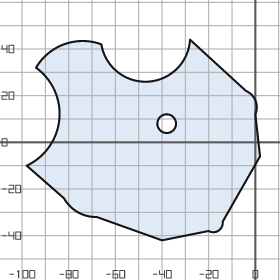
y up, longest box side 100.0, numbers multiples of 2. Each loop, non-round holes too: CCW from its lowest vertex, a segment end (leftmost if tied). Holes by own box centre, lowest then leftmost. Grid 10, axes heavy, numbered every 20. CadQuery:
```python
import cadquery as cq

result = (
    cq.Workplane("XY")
    .moveTo(-40.0, -42.0)
    .lineTo(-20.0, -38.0)
    .threePointArc((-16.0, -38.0), (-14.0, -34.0))
    .lineTo(2.0, -6.0)
    .lineTo(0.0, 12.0)
    .threePointArc((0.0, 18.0), (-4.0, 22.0))
    .lineTo(-28.0, 44.0)
    .threePointArc((-46.0, 26.0), (-66.0, 42.0))
    .threePointArc((-82.0, 42.0), (-94.0, 32.0))
    .threePointArc((-84.0, 10.0), (-98.0, -10.0))
    .lineTo(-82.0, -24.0)
    .threePointArc((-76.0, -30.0), (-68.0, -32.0))
    .close()
    .moveTo(-38.0, 8.0)
    .circle(4.0)
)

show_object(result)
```